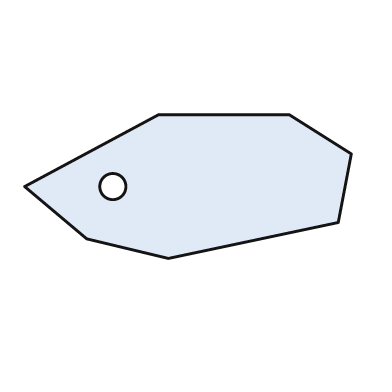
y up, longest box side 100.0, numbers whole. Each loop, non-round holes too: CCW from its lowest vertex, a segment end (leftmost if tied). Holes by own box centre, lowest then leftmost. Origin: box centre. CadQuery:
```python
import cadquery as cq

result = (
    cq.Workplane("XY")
    .moveTo(-6.0, -22.0)
    .lineTo(46.0, -11.0)
    .lineTo(50.0, 10.0)
    .lineTo(31.0, 22.0)
    .lineTo(-9.0, 22.0)
    .lineTo(-50.0, 0.0)
    .lineTo(-31.0, -16.0)
    .close()
    .moveTo(-23.0, 0.0)
    .circle(4.0)
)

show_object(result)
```